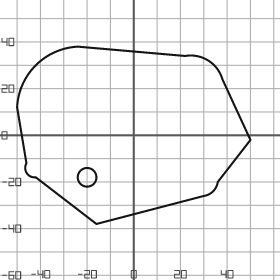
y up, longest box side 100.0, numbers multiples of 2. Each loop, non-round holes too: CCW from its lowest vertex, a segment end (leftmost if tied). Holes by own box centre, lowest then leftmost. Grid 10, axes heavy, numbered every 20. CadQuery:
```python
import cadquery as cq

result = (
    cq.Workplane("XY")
    .moveTo(-16.0, -38.0)
    .lineTo(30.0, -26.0)
    .threePointArc((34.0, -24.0), (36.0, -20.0))
    .lineTo(50.0, -2.0)
    .lineTo(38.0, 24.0)
    .threePointArc((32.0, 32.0), (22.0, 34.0))
    .lineTo(-24.0, 38.0)
    .threePointArc((-42.0, 30.0), (-50.0, 12.0))
    .lineTo(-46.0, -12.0)
    .threePointArc((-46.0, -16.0), (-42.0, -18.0))
    .close()
    .moveTo(-20.0, -18.0)
    .circle(4.0)
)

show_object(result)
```